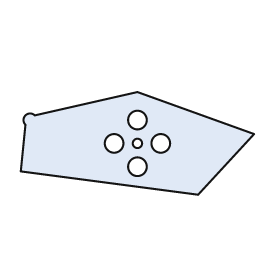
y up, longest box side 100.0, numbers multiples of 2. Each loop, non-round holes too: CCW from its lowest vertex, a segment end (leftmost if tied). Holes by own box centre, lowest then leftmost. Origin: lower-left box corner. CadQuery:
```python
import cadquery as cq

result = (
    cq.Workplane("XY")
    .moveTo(76.0, 0.0)
    .lineTo(100.0, 26.0)
    .lineTo(50.0, 44.0)
    .lineTo(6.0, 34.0)
    .threePointArc((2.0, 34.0), (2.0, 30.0))
    .lineTo(0.0, 10.0)
    .close()
    .moveTo(50.0, 12.0)
    .circle(4.0)
    .moveTo(40.0, 22.0)
    .circle(4.0)
    .moveTo(50.0, 22.0)
    .circle(2.0)
    .moveTo(60.0, 22.0)
    .circle(4.0)
    .moveTo(50.0, 32.0)
    .circle(4.0)
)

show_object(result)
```